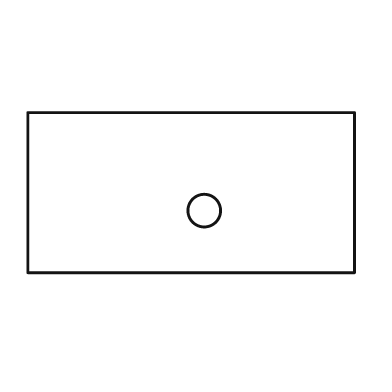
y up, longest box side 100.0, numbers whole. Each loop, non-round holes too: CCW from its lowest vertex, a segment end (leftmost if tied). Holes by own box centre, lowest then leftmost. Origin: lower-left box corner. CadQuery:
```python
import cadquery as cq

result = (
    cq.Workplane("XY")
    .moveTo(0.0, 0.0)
    .lineTo(100.0, 0.0)
    .lineTo(100.0, 49.0)
    .lineTo(0.0, 49.0)
    .close()
    .moveTo(54.0, 19.0)
    .circle(5.0)
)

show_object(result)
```